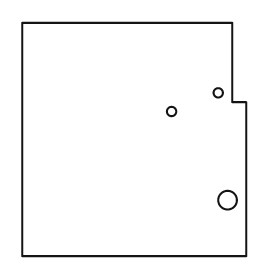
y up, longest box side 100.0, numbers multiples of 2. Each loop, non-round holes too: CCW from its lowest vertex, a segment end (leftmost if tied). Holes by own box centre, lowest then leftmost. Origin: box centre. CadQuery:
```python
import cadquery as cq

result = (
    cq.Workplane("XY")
    .moveTo(-48.0, -50.0)
    .lineTo(48.0, -50.0)
    .lineTo(48.0, 16.0)
    .lineTo(42.0, 16.0)
    .lineTo(42.0, 50.0)
    .lineTo(-48.0, 50.0)
    .close()
    .moveTo(40.0, -26.0)
    .circle(4.0)
    .moveTo(16.0, 12.0)
    .circle(2.0)
    .moveTo(36.0, 20.0)
    .circle(2.0)
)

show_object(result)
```